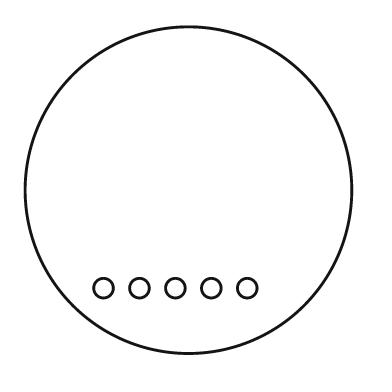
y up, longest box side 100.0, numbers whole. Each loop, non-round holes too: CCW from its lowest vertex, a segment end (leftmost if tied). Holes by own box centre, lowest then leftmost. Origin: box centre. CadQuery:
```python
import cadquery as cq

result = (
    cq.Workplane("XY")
    .moveTo(0.0, 0.0)
    .circle(50.0)
    .moveTo(-26.0, -30.0)
    .circle(3.0)
    .moveTo(-15.0, -30.0)
    .circle(3.0)
    .moveTo(-4.0, -30.0)
    .circle(3.0)
    .moveTo(7.0, -30.0)
    .circle(3.0)
    .moveTo(18.0, -30.0)
    .circle(3.0)
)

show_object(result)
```